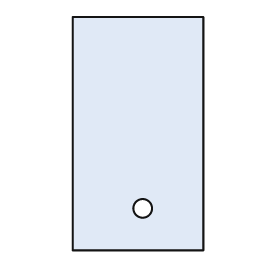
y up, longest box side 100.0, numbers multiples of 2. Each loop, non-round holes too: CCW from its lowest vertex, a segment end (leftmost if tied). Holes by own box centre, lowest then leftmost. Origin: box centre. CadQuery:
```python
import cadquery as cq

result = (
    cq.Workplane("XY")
    .moveTo(-28.0, -50.0)
    .lineTo(28.0, -50.0)
    .lineTo(28.0, 50.0)
    .lineTo(-28.0, 50.0)
    .close()
    .moveTo(2.0, -32.0)
    .circle(4.0)
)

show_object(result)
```